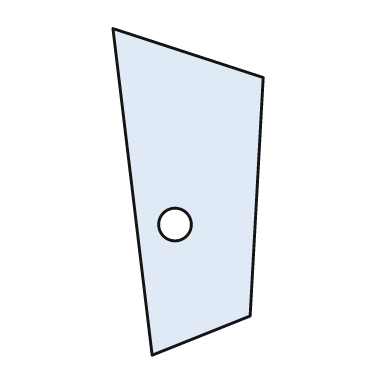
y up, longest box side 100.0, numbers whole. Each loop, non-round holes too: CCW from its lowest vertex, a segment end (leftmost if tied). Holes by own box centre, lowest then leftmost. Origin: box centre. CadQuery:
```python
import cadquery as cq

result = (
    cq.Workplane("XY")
    .moveTo(-11.0, -50.0)
    .lineTo(19.0, -38.0)
    .lineTo(23.0, 35.0)
    .lineTo(-23.0, 50.0)
    .close()
    .moveTo(-4.0, -10.0)
    .circle(5.0)
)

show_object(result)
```